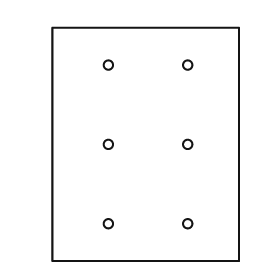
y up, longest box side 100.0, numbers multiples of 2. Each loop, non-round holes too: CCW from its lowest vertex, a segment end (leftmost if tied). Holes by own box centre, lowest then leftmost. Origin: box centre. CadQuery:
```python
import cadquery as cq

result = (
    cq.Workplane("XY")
    .moveTo(-40.0, -50.0)
    .lineTo(40.0, -50.0)
    .lineTo(40.0, 50.0)
    .lineTo(-40.0, 50.0)
    .close()
    .moveTo(-16.0, -34.0)
    .circle(2.0)
    .moveTo(18.0, -34.0)
    .circle(2.0)
    .moveTo(-16.0, 0.0)
    .circle(2.0)
    .moveTo(18.0, 0.0)
    .circle(2.0)
    .moveTo(-16.0, 34.0)
    .circle(2.0)
    .moveTo(18.0, 34.0)
    .circle(2.0)
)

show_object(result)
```